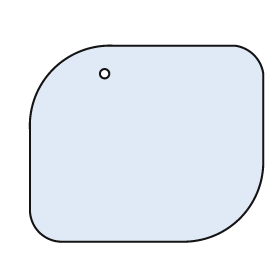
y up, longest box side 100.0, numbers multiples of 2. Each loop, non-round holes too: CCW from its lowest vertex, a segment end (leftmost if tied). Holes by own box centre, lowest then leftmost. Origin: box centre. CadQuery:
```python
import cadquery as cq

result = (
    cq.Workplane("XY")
    .moveTo(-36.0, -42.0)
    .lineTo(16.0, -42.0)
    .threePointArc((40.0, -32.0), (50.0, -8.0))
    .lineTo(50.0, 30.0)
    .threePointArc((46.0, 38.0), (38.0, 42.0))
    .lineTo(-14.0, 42.0)
    .threePointArc((-40.0, 32.0), (-50.0, 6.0))
    .lineTo(-50.0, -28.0)
    .threePointArc((-46.0, -38.0), (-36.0, -42.0))
    .close()
    .moveTo(-18.0, 30.0)
    .circle(2.0)
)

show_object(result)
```